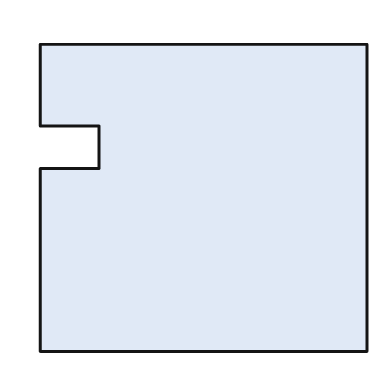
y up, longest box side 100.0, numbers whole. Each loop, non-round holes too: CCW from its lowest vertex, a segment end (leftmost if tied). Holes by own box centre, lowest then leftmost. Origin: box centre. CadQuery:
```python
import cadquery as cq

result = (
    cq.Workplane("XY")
    .moveTo(-50.0, -47.0)
    .lineTo(50.0, -47.0)
    .lineTo(50.0, 47.0)
    .lineTo(-50.0, 47.0)
    .lineTo(-50.0, 22.0)
    .lineTo(-32.0, 22.0)
    .lineTo(-32.0, 9.0)
    .lineTo(-50.0, 9.0)
    .close()
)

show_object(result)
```